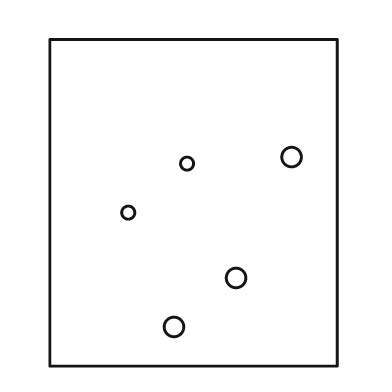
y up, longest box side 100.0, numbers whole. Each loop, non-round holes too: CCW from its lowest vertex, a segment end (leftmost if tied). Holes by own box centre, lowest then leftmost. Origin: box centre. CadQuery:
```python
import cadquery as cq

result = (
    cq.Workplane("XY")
    .moveTo(-44.0, -50.0)
    .lineTo(44.0, -50.0)
    .lineTo(44.0, 50.0)
    .lineTo(-44.0, 50.0)
    .close()
    .moveTo(-6.0, -38.0)
    .circle(3.0)
    .moveTo(13.0, -23.0)
    .circle(3.0)
    .moveTo(-20.0, -3.0)
    .circle(2.0)
    .moveTo(-2.0, 12.0)
    .circle(2.0)
    .moveTo(30.0, 14.0)
    .circle(3.0)
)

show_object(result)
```